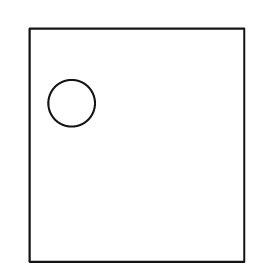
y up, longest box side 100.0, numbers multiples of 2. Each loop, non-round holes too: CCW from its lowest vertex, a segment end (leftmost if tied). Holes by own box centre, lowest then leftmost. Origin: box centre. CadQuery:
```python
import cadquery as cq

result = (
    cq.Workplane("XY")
    .moveTo(-46.0, -50.0)
    .lineTo(46.0, -50.0)
    .lineTo(46.0, 50.0)
    .lineTo(-46.0, 50.0)
    .close()
    .moveTo(-28.0, 18.0)
    .circle(10.0)
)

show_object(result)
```